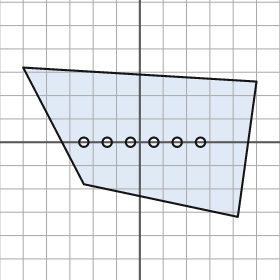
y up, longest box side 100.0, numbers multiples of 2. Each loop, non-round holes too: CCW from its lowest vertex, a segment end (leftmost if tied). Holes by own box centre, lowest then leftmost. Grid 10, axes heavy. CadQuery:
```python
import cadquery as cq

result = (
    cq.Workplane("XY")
    .moveTo(42.0, -32.0)
    .lineTo(50.0, 26.0)
    .lineTo(-50.0, 32.0)
    .lineTo(-24.0, -18.0)
    .close()
    .moveTo(-24.0, 0.0)
    .circle(2.0)
    .moveTo(-14.0, 0.0)
    .circle(2.0)
    .moveTo(-4.0, 0.0)
    .circle(2.0)
    .moveTo(6.0, 0.0)
    .circle(2.0)
    .moveTo(16.0, 0.0)
    .circle(2.0)
    .moveTo(26.0, 0.0)
    .circle(2.0)
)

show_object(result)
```